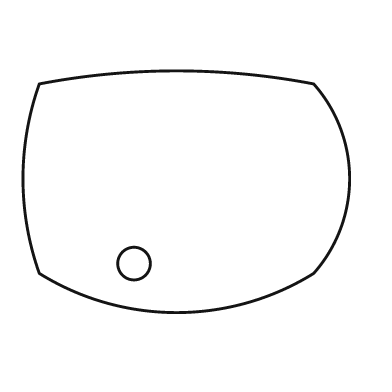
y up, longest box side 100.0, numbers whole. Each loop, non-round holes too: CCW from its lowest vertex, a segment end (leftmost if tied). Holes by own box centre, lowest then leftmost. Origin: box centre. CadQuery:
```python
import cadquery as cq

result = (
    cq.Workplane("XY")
    .moveTo(-45.0, -25.0)
    .threePointArc((-3.0, -37.0), (39.0, -25.0))
    .threePointArc((50.0, 4.0), (39.0, 33.0))
    .threePointArc((-3.0, 37.0), (-45.0, 33.0))
    .threePointArc((-50.0, 4.0), (-45.0, -25.0))
    .close()
    .moveTo(-16.0, -22.0)
    .circle(5.0)
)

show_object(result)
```